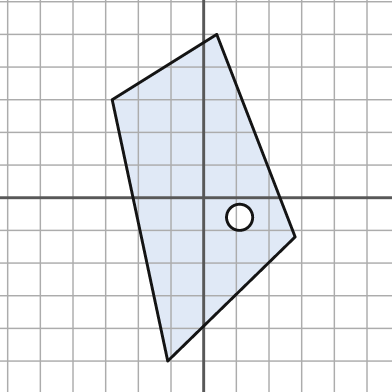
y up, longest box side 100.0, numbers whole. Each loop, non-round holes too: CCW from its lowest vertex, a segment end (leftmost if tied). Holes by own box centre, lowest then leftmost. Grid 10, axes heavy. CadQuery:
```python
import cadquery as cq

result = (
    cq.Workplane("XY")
    .moveTo(-11.0, -50.0)
    .lineTo(28.0, -12.0)
    .lineTo(4.0, 50.0)
    .lineTo(-28.0, 30.0)
    .close()
    .moveTo(11.0, -6.0)
    .circle(4.0)
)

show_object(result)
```